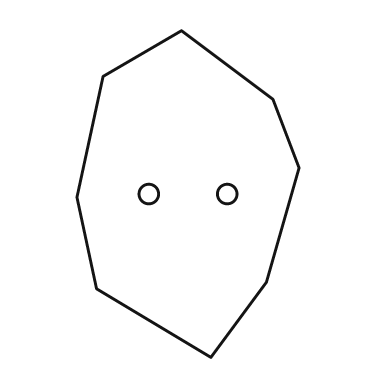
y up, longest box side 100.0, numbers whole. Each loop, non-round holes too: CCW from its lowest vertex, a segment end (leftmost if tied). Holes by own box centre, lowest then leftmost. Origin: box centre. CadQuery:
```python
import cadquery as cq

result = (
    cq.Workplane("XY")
    .moveTo(7.0, -50.0)
    .lineTo(24.0, -27.0)
    .lineTo(34.0, 8.0)
    .lineTo(26.0, 29.0)
    .lineTo(-2.0, 50.0)
    .lineTo(-26.0, 36.0)
    .lineTo(-34.0, -1.0)
    .lineTo(-28.0, -29.0)
    .close()
    .moveTo(-12.0, 0.0)
    .circle(3.0)
    .moveTo(12.0, 0.0)
    .circle(3.0)
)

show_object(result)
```